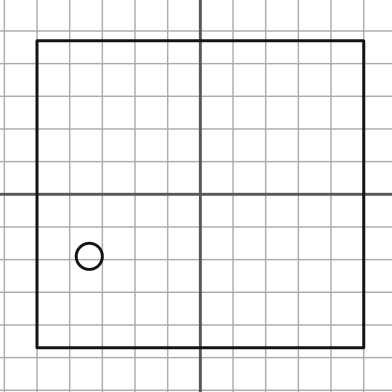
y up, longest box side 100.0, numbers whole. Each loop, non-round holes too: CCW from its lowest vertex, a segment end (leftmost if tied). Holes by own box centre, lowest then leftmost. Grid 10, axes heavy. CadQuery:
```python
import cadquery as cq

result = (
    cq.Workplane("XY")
    .moveTo(-50.0, -47.0)
    .lineTo(50.0, -47.0)
    .lineTo(50.0, 47.0)
    .lineTo(-50.0, 47.0)
    .close()
    .moveTo(-34.0, -19.0)
    .circle(4.0)
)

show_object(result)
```